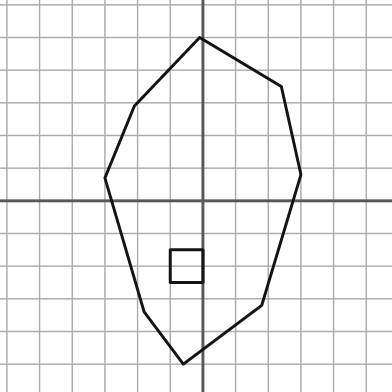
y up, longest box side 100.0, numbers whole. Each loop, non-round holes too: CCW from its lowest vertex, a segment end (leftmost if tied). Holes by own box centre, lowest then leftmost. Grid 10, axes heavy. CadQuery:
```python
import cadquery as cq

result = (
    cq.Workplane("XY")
    .moveTo(-6.0, -50.0)
    .lineTo(18.0, -32.0)
    .lineTo(30.0, 8.0)
    .lineTo(24.0, 35.0)
    .lineTo(-1.0, 50.0)
    .lineTo(-21.0, 29.0)
    .lineTo(-30.0, 7.0)
    .lineTo(-18.0, -34.0)
    .close()
    .moveTo(-10.0, -25.0)
    .lineTo(0.0, -25.0)
    .lineTo(0.0, -15.0)
    .lineTo(-10.0, -15.0)
    .close()
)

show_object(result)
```